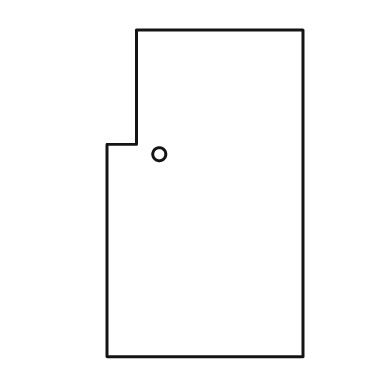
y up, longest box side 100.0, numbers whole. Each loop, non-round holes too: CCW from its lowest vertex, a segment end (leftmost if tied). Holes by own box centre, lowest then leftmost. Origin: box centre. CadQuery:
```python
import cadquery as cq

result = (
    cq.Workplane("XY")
    .moveTo(-30.0, -50.0)
    .lineTo(30.0, -50.0)
    .lineTo(30.0, 50.0)
    .lineTo(-21.0, 50.0)
    .lineTo(-21.0, 15.0)
    .lineTo(-30.0, 15.0)
    .close()
    .moveTo(-14.0, 12.0)
    .circle(2.0)
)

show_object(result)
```